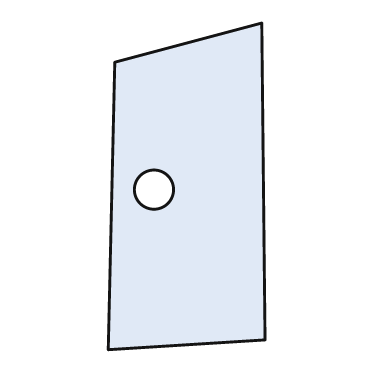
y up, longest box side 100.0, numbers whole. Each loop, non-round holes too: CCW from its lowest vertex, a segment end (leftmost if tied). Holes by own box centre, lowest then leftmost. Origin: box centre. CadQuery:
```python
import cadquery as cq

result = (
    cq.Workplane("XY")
    .moveTo(-24.0, -50.0)
    .lineTo(24.0, -47.0)
    .lineTo(23.0, 50.0)
    .lineTo(-22.0, 38.0)
    .close()
    .moveTo(-10.0, -1.0)
    .circle(6.0)
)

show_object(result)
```